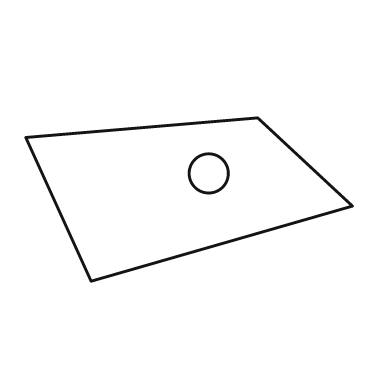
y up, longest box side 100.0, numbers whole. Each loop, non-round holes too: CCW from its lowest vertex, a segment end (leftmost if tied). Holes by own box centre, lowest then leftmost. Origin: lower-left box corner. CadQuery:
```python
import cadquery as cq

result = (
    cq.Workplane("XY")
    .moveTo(20.0, 0.0)
    .lineTo(100.0, 23.0)
    .lineTo(71.0, 50.0)
    .lineTo(0.0, 44.0)
    .close()
    .moveTo(56.0, 33.0)
    .circle(6.0)
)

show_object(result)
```